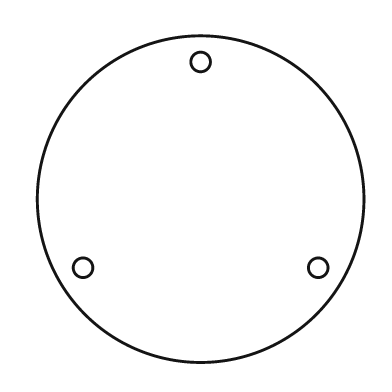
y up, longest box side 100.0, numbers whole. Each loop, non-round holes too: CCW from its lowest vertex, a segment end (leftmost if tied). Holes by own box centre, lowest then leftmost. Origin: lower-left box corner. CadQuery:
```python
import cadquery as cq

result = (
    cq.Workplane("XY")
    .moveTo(50.0, 50.0)
    .circle(50.0)
    .moveTo(14.0, 29.0)
    .circle(3.0)
    .moveTo(86.0, 29.0)
    .circle(3.0)
    .moveTo(50.0, 92.0)
    .circle(3.0)
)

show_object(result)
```